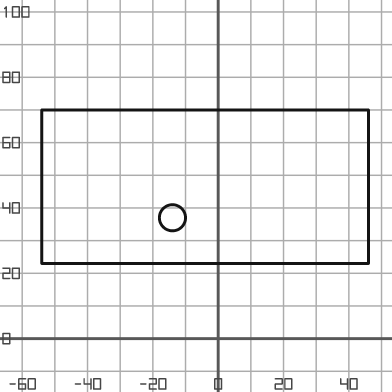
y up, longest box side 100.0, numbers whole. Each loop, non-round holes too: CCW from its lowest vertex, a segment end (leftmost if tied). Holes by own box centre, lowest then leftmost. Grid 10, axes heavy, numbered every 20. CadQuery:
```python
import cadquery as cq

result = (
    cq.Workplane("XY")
    .moveTo(-54.0, 23.0)
    .lineTo(46.0, 23.0)
    .lineTo(46.0, 70.0)
    .lineTo(-54.0, 70.0)
    .close()
    .moveTo(-14.0, 37.0)
    .circle(4.0)
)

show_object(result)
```